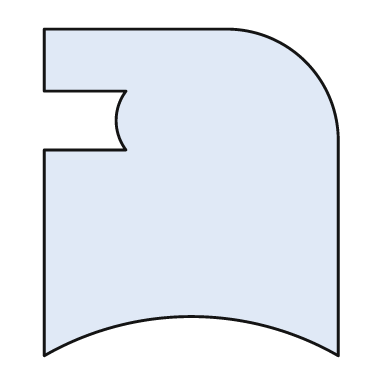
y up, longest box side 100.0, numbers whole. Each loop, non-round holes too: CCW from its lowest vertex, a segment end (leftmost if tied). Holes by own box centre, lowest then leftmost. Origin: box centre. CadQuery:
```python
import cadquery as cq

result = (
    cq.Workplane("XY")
    .moveTo(-45.0, -50.0)
    .threePointArc((0.0, -38.0), (45.0, -50.0))
    .lineTo(45.0, 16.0)
    .threePointArc((35.0, 40.0), (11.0, 50.0))
    .lineTo(-45.0, 50.0)
    .lineTo(-45.0, 31.0)
    .lineTo(-20.0, 31.0)
    .threePointArc((-23.0, 22.0), (-20.0, 13.0))
    .lineTo(-45.0, 13.0)
    .close()
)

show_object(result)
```